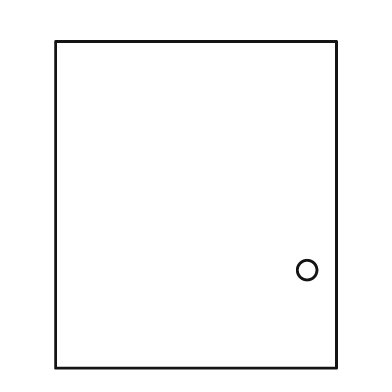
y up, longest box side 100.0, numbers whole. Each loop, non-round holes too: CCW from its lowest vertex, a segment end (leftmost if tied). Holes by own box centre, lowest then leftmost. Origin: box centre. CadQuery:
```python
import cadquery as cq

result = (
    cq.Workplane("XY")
    .moveTo(-43.0, -50.0)
    .lineTo(43.0, -50.0)
    .lineTo(43.0, 50.0)
    .lineTo(-43.0, 50.0)
    .close()
    .moveTo(34.0, -20.0)
    .circle(3.0)
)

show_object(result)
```